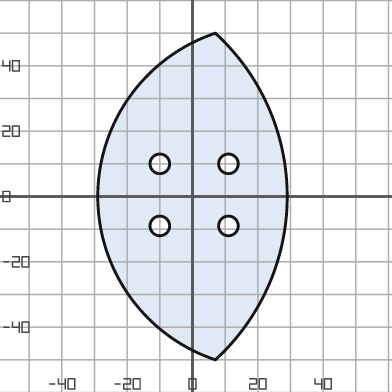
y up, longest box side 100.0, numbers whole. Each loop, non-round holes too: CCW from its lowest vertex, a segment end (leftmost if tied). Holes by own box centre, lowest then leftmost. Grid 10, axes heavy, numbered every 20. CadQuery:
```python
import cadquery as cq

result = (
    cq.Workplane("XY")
    .moveTo(7.0, -50.0)
    .threePointArc((29.0, 0.0), (7.0, 50.0))
    .threePointArc((-29.0, 0.0), (7.0, -50.0))
    .close()
    .moveTo(-10.0, -9.0)
    .circle(3.0)
    .moveTo(11.0, -9.0)
    .circle(3.0)
    .moveTo(-10.0, 10.0)
    .circle(3.0)
    .moveTo(11.0, 10.0)
    .circle(3.0)
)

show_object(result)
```